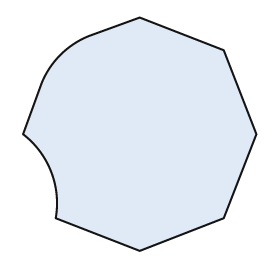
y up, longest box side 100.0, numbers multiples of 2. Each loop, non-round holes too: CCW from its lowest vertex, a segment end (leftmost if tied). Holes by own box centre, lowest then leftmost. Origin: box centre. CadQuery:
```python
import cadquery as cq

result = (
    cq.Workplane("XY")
    .moveTo(0.0, -50.0)
    .lineTo(36.0, -36.0)
    .lineTo(50.0, 0.0)
    .lineTo(36.0, 36.0)
    .lineTo(0.0, 50.0)
    .lineTo(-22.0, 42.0)
    .threePointArc((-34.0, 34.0), (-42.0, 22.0))
    .lineTo(-50.0, 0.0)
    .threePointArc((-38.0, -16.0), (-36.0, -36.0))
    .close()
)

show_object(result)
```